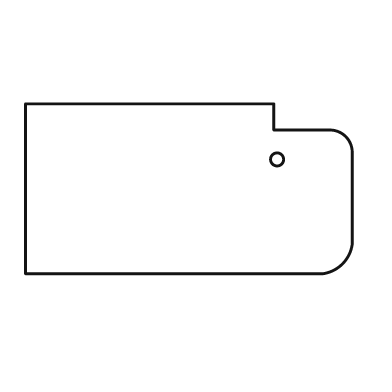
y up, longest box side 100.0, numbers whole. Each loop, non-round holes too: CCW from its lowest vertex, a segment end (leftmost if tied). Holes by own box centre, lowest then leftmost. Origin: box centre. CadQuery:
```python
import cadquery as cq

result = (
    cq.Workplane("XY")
    .moveTo(-50.0, -26.0)
    .lineTo(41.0, -26.0)
    .threePointArc((47.0, -23.0), (50.0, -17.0))
    .lineTo(50.0, 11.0)
    .threePointArc((48.0, 16.0), (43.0, 18.0))
    .lineTo(26.0, 18.0)
    .lineTo(26.0, 26.0)
    .lineTo(-50.0, 26.0)
    .close()
    .moveTo(27.0, 9.0)
    .circle(2.0)
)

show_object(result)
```